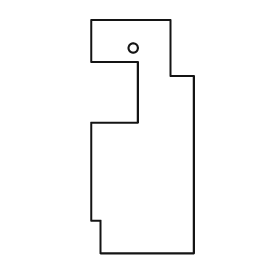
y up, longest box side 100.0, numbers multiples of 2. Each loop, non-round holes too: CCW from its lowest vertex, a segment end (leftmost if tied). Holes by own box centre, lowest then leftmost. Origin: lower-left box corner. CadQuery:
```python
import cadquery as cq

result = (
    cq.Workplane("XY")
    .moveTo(4.0, 0.0)
    .lineTo(44.0, 0.0)
    .lineTo(44.0, 76.0)
    .lineTo(34.0, 76.0)
    .lineTo(34.0, 100.0)
    .lineTo(0.0, 100.0)
    .lineTo(0.0, 82.0)
    .lineTo(20.0, 82.0)
    .lineTo(20.0, 56.0)
    .lineTo(0.0, 56.0)
    .lineTo(0.0, 14.0)
    .lineTo(4.0, 14.0)
    .close()
    .moveTo(18.0, 88.0)
    .circle(2.0)
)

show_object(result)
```